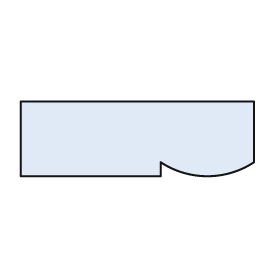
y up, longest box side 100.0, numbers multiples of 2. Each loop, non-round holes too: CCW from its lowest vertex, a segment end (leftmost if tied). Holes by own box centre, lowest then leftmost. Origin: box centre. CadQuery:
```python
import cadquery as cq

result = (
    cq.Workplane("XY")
    .moveTo(-50.0, -16.0)
    .lineTo(10.0, -16.0)
    .lineTo(10.0, -10.0)
    .threePointArc((30.0, -16.0), (50.0, -10.0))
    .lineTo(50.0, 16.0)
    .lineTo(-50.0, 16.0)
    .close()
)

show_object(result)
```